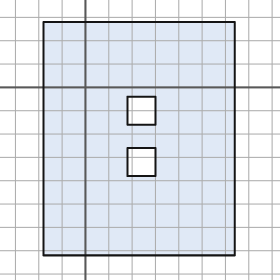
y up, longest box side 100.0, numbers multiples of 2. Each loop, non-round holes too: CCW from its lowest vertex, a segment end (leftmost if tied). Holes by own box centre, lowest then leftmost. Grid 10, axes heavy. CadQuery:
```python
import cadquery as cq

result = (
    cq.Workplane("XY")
    .moveTo(-18.0, -72.0)
    .lineTo(64.0, -72.0)
    .lineTo(64.0, 28.0)
    .lineTo(-18.0, 28.0)
    .close()
    .moveTo(18.0, -38.0)
    .lineTo(30.0, -38.0)
    .lineTo(30.0, -26.0)
    .lineTo(18.0, -26.0)
    .close()
    .moveTo(18.0, -16.0)
    .lineTo(30.0, -16.0)
    .lineTo(30.0, -4.0)
    .lineTo(18.0, -4.0)
    .close()
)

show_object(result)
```